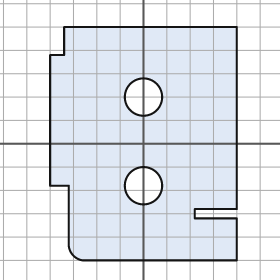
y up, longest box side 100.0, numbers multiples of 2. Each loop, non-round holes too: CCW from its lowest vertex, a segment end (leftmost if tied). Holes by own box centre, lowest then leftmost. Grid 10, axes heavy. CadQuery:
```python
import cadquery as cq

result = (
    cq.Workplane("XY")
    .moveTo(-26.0, -50.0)
    .lineTo(40.0, -50.0)
    .lineTo(40.0, -32.0)
    .lineTo(22.0, -32.0)
    .lineTo(22.0, -28.0)
    .lineTo(40.0, -28.0)
    .lineTo(40.0, 50.0)
    .lineTo(-34.0, 50.0)
    .lineTo(-34.0, 38.0)
    .lineTo(-40.0, 38.0)
    .lineTo(-40.0, -18.0)
    .lineTo(-32.0, -18.0)
    .lineTo(-32.0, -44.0)
    .threePointArc((-30.0, -48.0), (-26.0, -50.0))
    .close()
    .moveTo(0.0, -18.0)
    .circle(8.0)
    .moveTo(0.0, 20.0)
    .circle(8.0)
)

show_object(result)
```